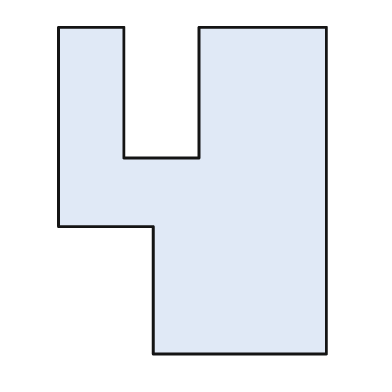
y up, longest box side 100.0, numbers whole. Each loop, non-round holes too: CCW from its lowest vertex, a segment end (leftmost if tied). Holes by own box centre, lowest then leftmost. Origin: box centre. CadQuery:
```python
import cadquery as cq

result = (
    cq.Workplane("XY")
    .moveTo(-12.0, -50.0)
    .lineTo(41.0, -50.0)
    .lineTo(41.0, 50.0)
    .lineTo(2.0, 50.0)
    .lineTo(2.0, 10.0)
    .lineTo(-21.0, 10.0)
    .lineTo(-21.0, 50.0)
    .lineTo(-41.0, 50.0)
    .lineTo(-41.0, -11.0)
    .lineTo(-12.0, -11.0)
    .close()
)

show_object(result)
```